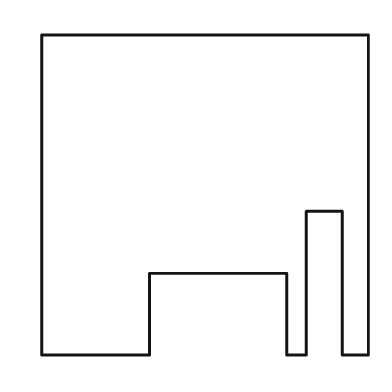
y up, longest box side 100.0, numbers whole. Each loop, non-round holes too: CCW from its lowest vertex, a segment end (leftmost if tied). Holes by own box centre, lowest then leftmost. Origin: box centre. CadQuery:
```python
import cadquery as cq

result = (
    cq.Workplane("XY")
    .moveTo(-50.0, -49.0)
    .lineTo(-17.0, -49.0)
    .lineTo(-17.0, -24.0)
    .lineTo(25.0, -24.0)
    .lineTo(25.0, -49.0)
    .lineTo(31.0, -49.0)
    .lineTo(31.0, -5.0)
    .lineTo(42.0, -5.0)
    .lineTo(42.0, -49.0)
    .lineTo(50.0, -49.0)
    .lineTo(50.0, 49.0)
    .lineTo(-50.0, 49.0)
    .close()
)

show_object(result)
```